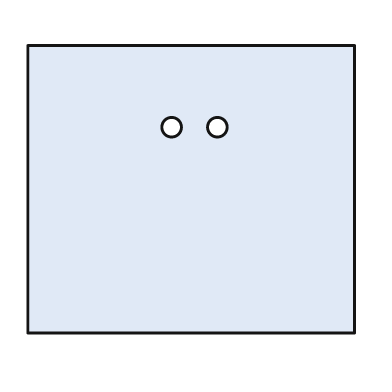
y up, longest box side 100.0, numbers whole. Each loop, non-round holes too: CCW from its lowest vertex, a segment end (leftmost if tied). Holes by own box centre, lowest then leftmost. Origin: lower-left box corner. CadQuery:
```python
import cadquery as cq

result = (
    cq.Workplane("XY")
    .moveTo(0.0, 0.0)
    .lineTo(100.0, 0.0)
    .lineTo(100.0, 88.0)
    .lineTo(0.0, 88.0)
    .close()
    .moveTo(44.0, 63.0)
    .circle(3.0)
    .moveTo(58.0, 63.0)
    .circle(3.0)
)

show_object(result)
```